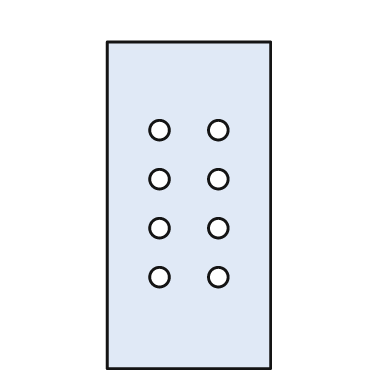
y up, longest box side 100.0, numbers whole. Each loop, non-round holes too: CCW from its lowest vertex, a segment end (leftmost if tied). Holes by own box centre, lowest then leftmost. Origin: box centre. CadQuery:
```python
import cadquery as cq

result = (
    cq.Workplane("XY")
    .moveTo(-25.0, -50.0)
    .lineTo(25.0, -50.0)
    .lineTo(25.0, 50.0)
    .lineTo(-25.0, 50.0)
    .close()
    .moveTo(-9.0, -22.0)
    .circle(3.0)
    .moveTo(9.0, -22.0)
    .circle(3.0)
    .moveTo(-9.0, -7.0)
    .circle(3.0)
    .moveTo(9.0, -7.0)
    .circle(3.0)
    .moveTo(-9.0, 8.0)
    .circle(3.0)
    .moveTo(9.0, 8.0)
    .circle(3.0)
    .moveTo(-9.0, 23.0)
    .circle(3.0)
    .moveTo(9.0, 23.0)
    .circle(3.0)
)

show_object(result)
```